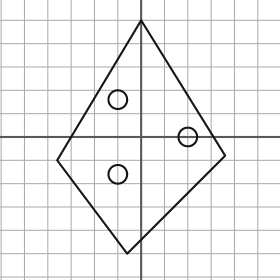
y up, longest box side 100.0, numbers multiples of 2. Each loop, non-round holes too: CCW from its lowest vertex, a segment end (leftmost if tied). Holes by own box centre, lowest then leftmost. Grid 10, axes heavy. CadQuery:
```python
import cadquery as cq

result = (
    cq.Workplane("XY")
    .moveTo(-6.0, -50.0)
    .lineTo(36.0, -8.0)
    .lineTo(0.0, 50.0)
    .lineTo(-36.0, -10.0)
    .close()
    .moveTo(-10.0, -16.0)
    .circle(4.0)
    .moveTo(20.0, 0.0)
    .circle(4.0)
    .moveTo(-10.0, 16.0)
    .circle(4.0)
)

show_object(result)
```